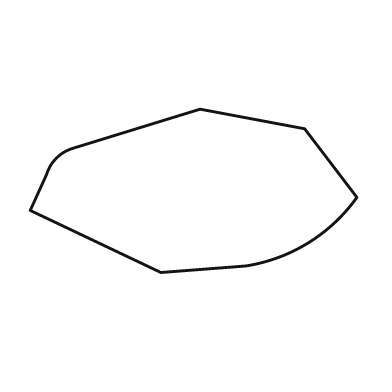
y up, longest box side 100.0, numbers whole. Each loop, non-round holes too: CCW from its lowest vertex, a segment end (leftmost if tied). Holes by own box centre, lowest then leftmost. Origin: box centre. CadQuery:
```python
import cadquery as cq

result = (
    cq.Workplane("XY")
    .moveTo(-10.0, -25.0)
    .lineTo(16.0, -23.0)
    .threePointArc((35.0, -16.0), (50.0, -2.0))
    .lineTo(34.0, 19.0)
    .lineTo(2.0, 25.0)
    .lineTo(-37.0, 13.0)
    .threePointArc((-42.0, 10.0), (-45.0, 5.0))
    .lineTo(-50.0, -6.0)
    .close()
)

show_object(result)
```